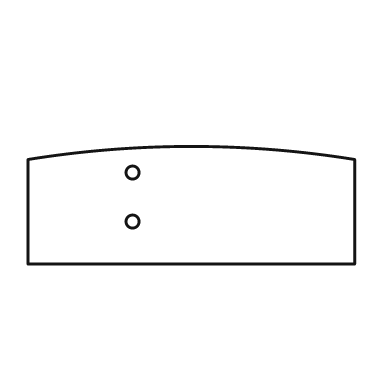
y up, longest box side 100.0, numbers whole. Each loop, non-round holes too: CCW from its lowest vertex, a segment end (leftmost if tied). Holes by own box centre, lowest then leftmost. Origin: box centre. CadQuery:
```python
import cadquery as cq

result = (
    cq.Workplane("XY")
    .moveTo(-50.0, -18.0)
    .lineTo(50.0, -18.0)
    .lineTo(50.0, 14.0)
    .threePointArc((0.0, 18.0), (-50.0, 14.0))
    .close()
    .moveTo(-18.0, -5.0)
    .circle(2.0)
    .moveTo(-18.0, 10.0)
    .circle(2.0)
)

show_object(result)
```